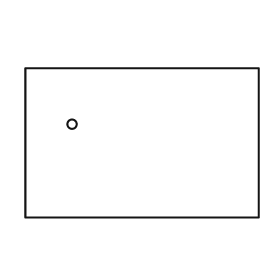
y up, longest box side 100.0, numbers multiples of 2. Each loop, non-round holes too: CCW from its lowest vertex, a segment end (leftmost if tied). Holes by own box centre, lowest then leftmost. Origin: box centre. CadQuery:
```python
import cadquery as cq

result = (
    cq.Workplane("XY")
    .moveTo(-50.0, -32.0)
    .lineTo(50.0, -32.0)
    .lineTo(50.0, 32.0)
    .lineTo(-50.0, 32.0)
    .close()
    .moveTo(-30.0, 8.0)
    .circle(2.0)
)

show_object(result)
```